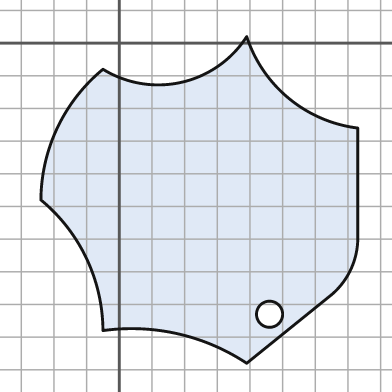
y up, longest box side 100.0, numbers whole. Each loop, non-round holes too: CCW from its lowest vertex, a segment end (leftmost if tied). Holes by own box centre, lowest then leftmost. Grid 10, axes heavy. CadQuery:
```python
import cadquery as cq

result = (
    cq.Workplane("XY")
    .moveTo(39.0, -98.0)
    .lineTo(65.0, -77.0)
    .threePointArc((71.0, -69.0), (73.0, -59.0))
    .lineTo(73.0, -26.0)
    .threePointArc((52.0, -17.0), (39.0, 2.0))
    .threePointArc((19.0, -12.0), (-5.0, -8.0))
    .threePointArc((-19.0, -26.0), (-24.0, -48.0))
    .threePointArc((-10.0, -66.0), (-5.0, -88.0))
    .threePointArc((18.0, -89.0), (39.0, -98.0))
    .close()
    .moveTo(46.0, -83.0)
    .circle(4.0)
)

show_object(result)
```